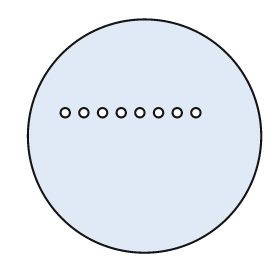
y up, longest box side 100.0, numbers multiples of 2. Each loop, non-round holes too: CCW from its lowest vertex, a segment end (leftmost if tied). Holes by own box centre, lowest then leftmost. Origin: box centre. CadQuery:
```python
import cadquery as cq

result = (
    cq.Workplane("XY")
    .moveTo(0.0, 0.0)
    .circle(50.0)
    .moveTo(-34.0, 10.0)
    .circle(2.0)
    .moveTo(-26.0, 10.0)
    .circle(2.0)
    .moveTo(-18.0, 10.0)
    .circle(2.0)
    .moveTo(-10.0, 10.0)
    .circle(2.0)
    .moveTo(-2.0, 10.0)
    .circle(2.0)
    .moveTo(6.0, 10.0)
    .circle(2.0)
    .moveTo(14.0, 10.0)
    .circle(2.0)
    .moveTo(22.0, 10.0)
    .circle(2.0)
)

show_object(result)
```